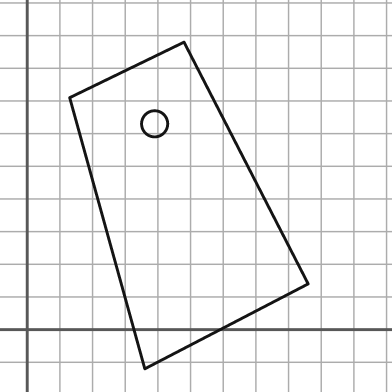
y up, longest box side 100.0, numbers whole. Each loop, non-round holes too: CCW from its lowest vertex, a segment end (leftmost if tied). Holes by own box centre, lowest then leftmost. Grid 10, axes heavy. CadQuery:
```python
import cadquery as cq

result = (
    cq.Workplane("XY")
    .moveTo(36.0, -12.0)
    .lineTo(86.0, 14.0)
    .lineTo(48.0, 88.0)
    .lineTo(13.0, 71.0)
    .close()
    .moveTo(39.0, 63.0)
    .circle(4.0)
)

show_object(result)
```